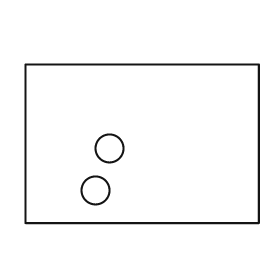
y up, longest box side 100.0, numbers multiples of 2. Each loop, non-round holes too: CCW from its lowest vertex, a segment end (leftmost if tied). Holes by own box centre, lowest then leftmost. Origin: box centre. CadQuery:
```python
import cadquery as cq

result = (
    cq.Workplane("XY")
    .moveTo(-50.0, -34.0)
    .lineTo(50.0, -34.0)
    .lineTo(50.0, 34.0)
    .lineTo(-50.0, 34.0)
    .close()
    .moveTo(-20.0, -20.0)
    .circle(6.0)
    .moveTo(-14.0, -2.0)
    .circle(6.0)
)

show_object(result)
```